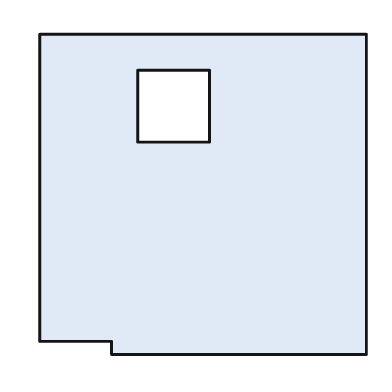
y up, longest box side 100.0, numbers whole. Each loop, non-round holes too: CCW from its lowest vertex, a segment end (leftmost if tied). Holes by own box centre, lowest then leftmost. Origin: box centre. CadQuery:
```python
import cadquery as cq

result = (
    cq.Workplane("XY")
    .moveTo(-28.0, -49.0)
    .lineTo(50.0, -49.0)
    .lineTo(50.0, 49.0)
    .lineTo(-50.0, 49.0)
    .lineTo(-50.0, -45.0)
    .lineTo(-28.0, -45.0)
    .close()
    .moveTo(-20.0, 16.0)
    .lineTo(2.0, 16.0)
    .lineTo(2.0, 38.0)
    .lineTo(-20.0, 38.0)
    .close()
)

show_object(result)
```